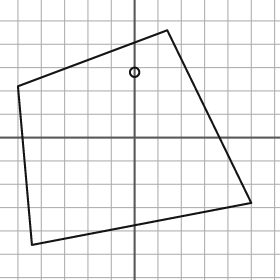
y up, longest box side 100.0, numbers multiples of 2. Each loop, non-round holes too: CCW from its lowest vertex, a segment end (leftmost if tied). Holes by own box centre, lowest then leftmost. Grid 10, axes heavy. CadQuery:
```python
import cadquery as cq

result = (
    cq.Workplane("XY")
    .moveTo(-44.0, -46.0)
    .lineTo(50.0, -28.0)
    .lineTo(14.0, 46.0)
    .lineTo(-50.0, 22.0)
    .close()
    .moveTo(0.0, 28.0)
    .circle(2.0)
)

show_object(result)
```